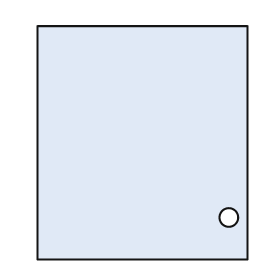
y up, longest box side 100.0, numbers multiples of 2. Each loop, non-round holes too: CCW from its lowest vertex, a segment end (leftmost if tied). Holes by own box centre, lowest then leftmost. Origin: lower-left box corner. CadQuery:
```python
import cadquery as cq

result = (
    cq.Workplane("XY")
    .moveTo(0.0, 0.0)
    .lineTo(90.0, 0.0)
    .lineTo(90.0, 100.0)
    .lineTo(0.0, 100.0)
    .close()
    .moveTo(82.0, 18.0)
    .circle(4.0)
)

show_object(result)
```